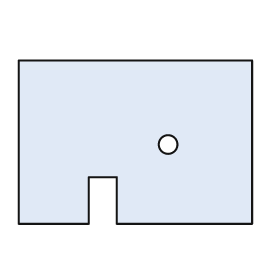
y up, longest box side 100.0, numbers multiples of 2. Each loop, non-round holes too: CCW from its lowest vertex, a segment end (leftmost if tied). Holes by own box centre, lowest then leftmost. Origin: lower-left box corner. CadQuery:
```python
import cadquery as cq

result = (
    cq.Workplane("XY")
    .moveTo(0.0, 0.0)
    .lineTo(30.0, 0.0)
    .lineTo(30.0, 20.0)
    .lineTo(42.0, 20.0)
    .lineTo(42.0, 0.0)
    .lineTo(100.0, 0.0)
    .lineTo(100.0, 70.0)
    .lineTo(0.0, 70.0)
    .close()
    .moveTo(64.0, 34.0)
    .circle(4.0)
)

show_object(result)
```